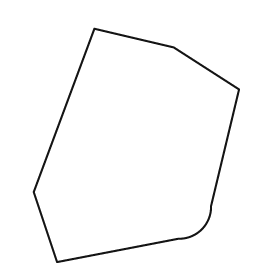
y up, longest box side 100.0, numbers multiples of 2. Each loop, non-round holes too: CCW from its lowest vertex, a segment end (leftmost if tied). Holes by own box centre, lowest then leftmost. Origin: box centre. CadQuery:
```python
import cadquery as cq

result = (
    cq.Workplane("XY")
    .moveTo(-34.0, -50.0)
    .lineTo(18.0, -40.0)
    .threePointArc((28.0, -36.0), (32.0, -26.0))
    .lineTo(44.0, 24.0)
    .lineTo(16.0, 42.0)
    .lineTo(-18.0, 50.0)
    .lineTo(-44.0, -20.0)
    .close()
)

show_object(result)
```